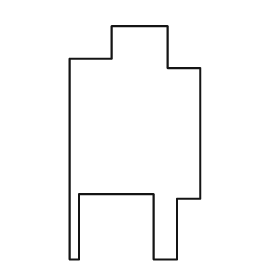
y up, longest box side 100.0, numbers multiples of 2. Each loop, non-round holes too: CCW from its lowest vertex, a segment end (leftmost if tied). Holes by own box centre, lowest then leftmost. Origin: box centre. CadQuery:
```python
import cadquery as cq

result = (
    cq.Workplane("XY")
    .moveTo(-28.0, -50.0)
    .lineTo(-24.0, -50.0)
    .lineTo(-24.0, -22.0)
    .lineTo(8.0, -22.0)
    .lineTo(8.0, -50.0)
    .lineTo(18.0, -50.0)
    .lineTo(18.0, -24.0)
    .lineTo(28.0, -24.0)
    .lineTo(28.0, 32.0)
    .lineTo(14.0, 32.0)
    .lineTo(14.0, 50.0)
    .lineTo(-10.0, 50.0)
    .lineTo(-10.0, 36.0)
    .lineTo(-28.0, 36.0)
    .close()
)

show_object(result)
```